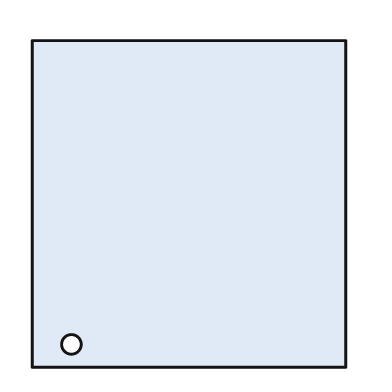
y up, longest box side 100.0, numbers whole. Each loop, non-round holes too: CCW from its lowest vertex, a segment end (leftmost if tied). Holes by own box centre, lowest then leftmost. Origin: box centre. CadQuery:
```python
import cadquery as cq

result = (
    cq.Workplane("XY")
    .moveTo(-48.0, -50.0)
    .lineTo(48.0, -50.0)
    .lineTo(48.0, 50.0)
    .lineTo(-48.0, 50.0)
    .close()
    .moveTo(-36.0, -43.0)
    .circle(3.0)
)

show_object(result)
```